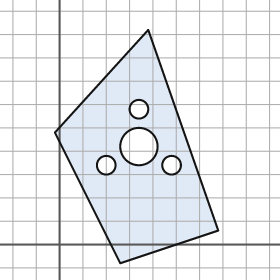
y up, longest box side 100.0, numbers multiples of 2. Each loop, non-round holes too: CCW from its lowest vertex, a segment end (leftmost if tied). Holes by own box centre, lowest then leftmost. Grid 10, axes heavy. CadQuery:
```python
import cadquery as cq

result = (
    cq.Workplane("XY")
    .moveTo(26.0, -8.0)
    .lineTo(68.0, 6.0)
    .lineTo(38.0, 92.0)
    .lineTo(-2.0, 48.0)
    .close()
    .moveTo(20.0, 34.0)
    .circle(4.0)
    .moveTo(48.0, 34.0)
    .circle(4.0)
    .moveTo(34.0, 42.0)
    .circle(8.0)
    .moveTo(34.0, 58.0)
    .circle(4.0)
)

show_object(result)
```